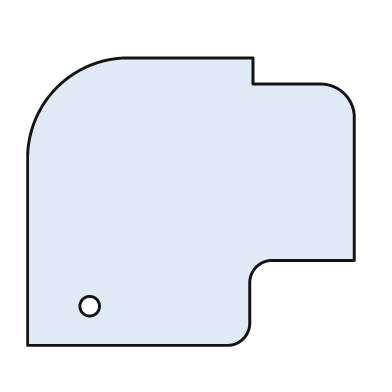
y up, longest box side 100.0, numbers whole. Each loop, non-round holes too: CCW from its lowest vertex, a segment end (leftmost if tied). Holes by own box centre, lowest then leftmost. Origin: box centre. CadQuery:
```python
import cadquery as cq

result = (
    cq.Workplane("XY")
    .moveTo(-50.0, -44.0)
    .lineTo(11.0, -44.0)
    .threePointArc((16.0, -42.0), (18.0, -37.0))
    .lineTo(18.0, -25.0)
    .threePointArc((20.0, -20.0), (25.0, -18.0))
    .lineTo(50.0, -18.0)
    .lineTo(50.0, 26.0)
    .threePointArc((47.0, 33.0), (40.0, 36.0))
    .lineTo(19.0, 36.0)
    .lineTo(19.0, 44.0)
    .lineTo(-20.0, 44.0)
    .threePointArc((-41.0, 35.0), (-50.0, 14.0))
    .close()
    .moveTo(-31.0, -32.0)
    .circle(3.0)
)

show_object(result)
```